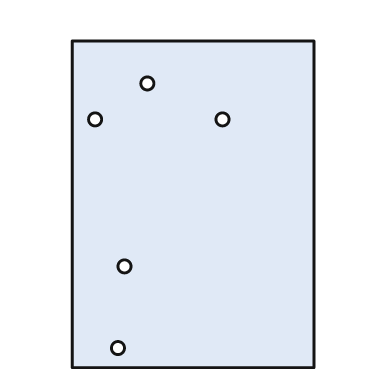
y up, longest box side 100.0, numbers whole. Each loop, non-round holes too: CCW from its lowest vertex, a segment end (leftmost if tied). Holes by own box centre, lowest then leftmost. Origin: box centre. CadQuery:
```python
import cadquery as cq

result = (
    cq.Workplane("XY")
    .moveTo(-37.0, -50.0)
    .lineTo(37.0, -50.0)
    .lineTo(37.0, 50.0)
    .lineTo(-37.0, 50.0)
    .close()
    .moveTo(-23.0, -44.0)
    .circle(2.0)
    .moveTo(-21.0, -19.0)
    .circle(2.0)
    .moveTo(-30.0, 26.0)
    .circle(2.0)
    .moveTo(9.0, 26.0)
    .circle(2.0)
    .moveTo(-14.0, 37.0)
    .circle(2.0)
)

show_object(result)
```